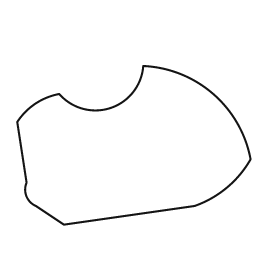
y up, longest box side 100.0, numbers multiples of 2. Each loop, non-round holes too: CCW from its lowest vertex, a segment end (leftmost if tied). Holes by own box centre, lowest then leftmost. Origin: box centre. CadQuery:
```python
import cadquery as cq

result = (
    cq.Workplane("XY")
    .moveTo(-30.0, -34.0)
    .lineTo(26.0, -26.0)
    .threePointArc((40.0, -18.0), (50.0, -6.0))
    .threePointArc((34.0, 22.0), (4.0, 34.0))
    .threePointArc((-10.0, 16.0), (-32.0, 22.0))
    .threePointArc((-42.0, 18.0), (-50.0, 10.0))
    .lineTo(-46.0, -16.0)
    .threePointArc((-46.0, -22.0), (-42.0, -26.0))
    .close()
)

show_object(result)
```